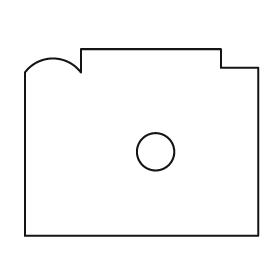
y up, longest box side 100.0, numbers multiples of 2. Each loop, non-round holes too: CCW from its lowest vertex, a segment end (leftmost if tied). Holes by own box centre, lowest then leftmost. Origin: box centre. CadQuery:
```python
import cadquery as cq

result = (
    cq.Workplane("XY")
    .moveTo(-50.0, -40.0)
    .lineTo(50.0, -40.0)
    .lineTo(50.0, 32.0)
    .lineTo(34.0, 32.0)
    .lineTo(34.0, 40.0)
    .lineTo(-26.0, 40.0)
    .lineTo(-26.0, 30.0)
    .threePointArc((-38.0, 36.0), (-50.0, 30.0))
    .close()
    .moveTo(6.0, -4.0)
    .circle(8.0)
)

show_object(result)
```